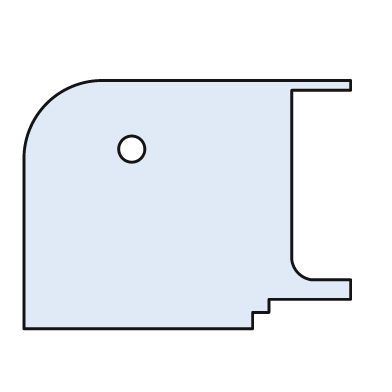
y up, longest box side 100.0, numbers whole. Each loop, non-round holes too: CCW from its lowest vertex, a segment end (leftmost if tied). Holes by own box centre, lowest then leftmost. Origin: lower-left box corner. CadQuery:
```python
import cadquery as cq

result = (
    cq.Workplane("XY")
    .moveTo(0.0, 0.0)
    .lineTo(70.0, 0.0)
    .lineTo(70.0, 5.0)
    .lineTo(75.0, 5.0)
    .lineTo(75.0, 9.0)
    .lineTo(100.0, 9.0)
    .lineTo(100.0, 15.0)
    .lineTo(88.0, 15.0)
    .threePointArc((84.0, 17.0), (82.0, 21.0))
    .lineTo(82.0, 73.0)
    .lineTo(100.0, 73.0)
    .lineTo(100.0, 76.0)
    .lineTo(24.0, 76.0)
    .threePointArc((7.0, 69.0), (0.0, 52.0))
    .close()
    .moveTo(33.0, 55.0)
    .circle(4.0)
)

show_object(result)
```